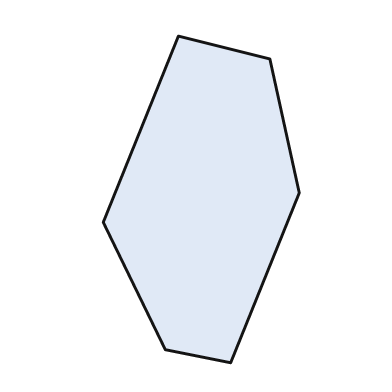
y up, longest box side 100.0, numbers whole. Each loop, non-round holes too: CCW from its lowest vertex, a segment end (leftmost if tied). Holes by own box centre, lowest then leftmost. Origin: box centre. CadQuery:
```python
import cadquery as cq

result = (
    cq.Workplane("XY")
    .moveTo(9.0, -50.0)
    .lineTo(30.0, 2.0)
    .lineTo(21.0, 43.0)
    .lineTo(-7.0, 50.0)
    .lineTo(-30.0, -7.0)
    .lineTo(-11.0, -46.0)
    .close()
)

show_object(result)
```